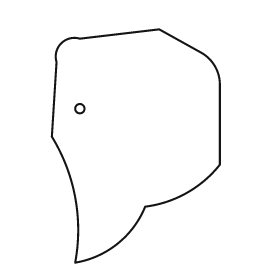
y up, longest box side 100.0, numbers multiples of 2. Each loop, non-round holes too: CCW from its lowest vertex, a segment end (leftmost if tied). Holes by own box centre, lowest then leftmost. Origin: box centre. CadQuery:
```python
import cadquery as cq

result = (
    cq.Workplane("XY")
    .moveTo(-26.0, -50.0)
    .threePointArc((-8.0, -42.0), (4.0, -26.0))
    .threePointArc((22.0, -20.0), (36.0, -8.0))
    .lineTo(36.0, 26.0)
    .threePointArc((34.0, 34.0), (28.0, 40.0))
    .lineTo(10.0, 50.0)
    .lineTo(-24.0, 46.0)
    .threePointArc((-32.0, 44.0), (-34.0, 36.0))
    .lineTo(-36.0, 4.0)
    .threePointArc((-26.0, -22.0), (-26.0, -50.0))
    .close()
    .moveTo(-24.0, 16.0)
    .circle(2.0)
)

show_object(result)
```